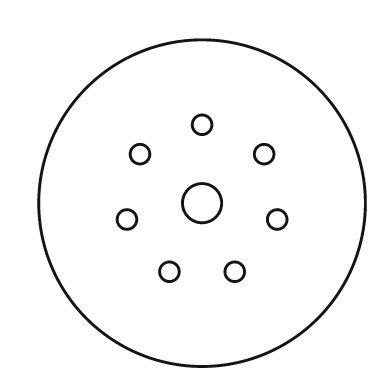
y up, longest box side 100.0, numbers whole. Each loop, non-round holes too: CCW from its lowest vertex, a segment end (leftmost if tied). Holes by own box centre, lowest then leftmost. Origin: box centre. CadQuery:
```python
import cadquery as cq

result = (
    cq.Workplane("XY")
    .moveTo(0.0, 0.0)
    .circle(50.0)
    .moveTo(-10.0, -21.0)
    .circle(3.0)
    .moveTo(10.0, -21.0)
    .circle(3.0)
    .moveTo(-23.0, -5.0)
    .circle(3.0)
    .moveTo(23.0, -5.0)
    .circle(3.0)
    .moveTo(0.0, 0.0)
    .circle(6.0)
    .moveTo(-19.0, 15.0)
    .circle(3.0)
    .moveTo(19.0, 15.0)
    .circle(3.0)
    .moveTo(0.0, 24.0)
    .circle(3.0)
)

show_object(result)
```